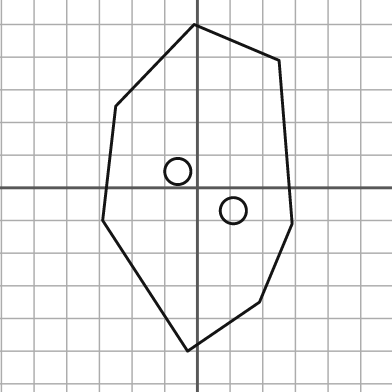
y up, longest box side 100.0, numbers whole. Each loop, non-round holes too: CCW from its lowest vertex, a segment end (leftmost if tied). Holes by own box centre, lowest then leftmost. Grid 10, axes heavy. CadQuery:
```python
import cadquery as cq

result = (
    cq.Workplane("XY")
    .moveTo(-3.0, -50.0)
    .lineTo(19.0, -35.0)
    .lineTo(29.0, -11.0)
    .lineTo(25.0, 39.0)
    .lineTo(-1.0, 50.0)
    .lineTo(-25.0, 25.0)
    .lineTo(-29.0, -10.0)
    .close()
    .moveTo(11.0, -7.0)
    .circle(4.0)
    .moveTo(-6.0, 5.0)
    .circle(4.0)
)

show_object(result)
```